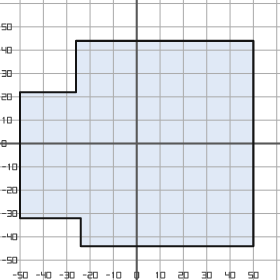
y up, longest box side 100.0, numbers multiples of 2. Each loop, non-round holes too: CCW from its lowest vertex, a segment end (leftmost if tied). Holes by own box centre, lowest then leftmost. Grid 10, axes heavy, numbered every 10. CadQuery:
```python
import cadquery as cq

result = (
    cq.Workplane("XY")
    .moveTo(-24.0, -44.0)
    .lineTo(50.0, -44.0)
    .lineTo(50.0, 44.0)
    .lineTo(-26.0, 44.0)
    .lineTo(-26.0, 22.0)
    .lineTo(-50.0, 22.0)
    .lineTo(-50.0, -32.0)
    .lineTo(-24.0, -32.0)
    .close()
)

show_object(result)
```